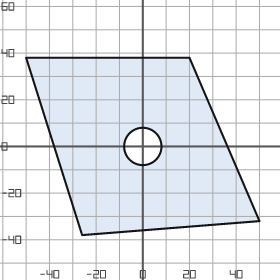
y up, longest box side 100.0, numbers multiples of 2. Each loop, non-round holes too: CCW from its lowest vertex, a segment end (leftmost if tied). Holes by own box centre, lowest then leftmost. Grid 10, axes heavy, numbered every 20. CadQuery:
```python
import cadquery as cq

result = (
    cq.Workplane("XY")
    .moveTo(-26.0, -38.0)
    .lineTo(50.0, -32.0)
    .lineTo(20.0, 38.0)
    .lineTo(-50.0, 38.0)
    .close()
    .moveTo(0.0, 0.0)
    .circle(8.0)
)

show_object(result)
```